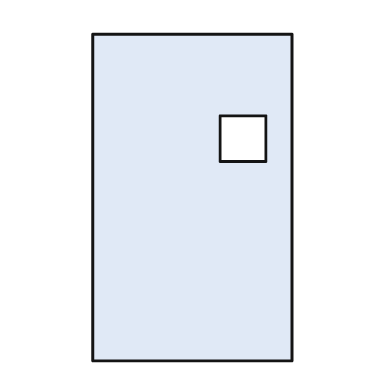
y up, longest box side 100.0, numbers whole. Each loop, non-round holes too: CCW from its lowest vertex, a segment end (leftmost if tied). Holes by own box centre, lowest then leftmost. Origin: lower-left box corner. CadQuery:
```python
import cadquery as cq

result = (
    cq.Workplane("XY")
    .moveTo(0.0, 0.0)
    .lineTo(61.0, 0.0)
    .lineTo(61.0, 100.0)
    .lineTo(0.0, 100.0)
    .close()
    .moveTo(39.0, 61.0)
    .lineTo(53.0, 61.0)
    .lineTo(53.0, 75.0)
    .lineTo(39.0, 75.0)
    .close()
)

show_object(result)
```